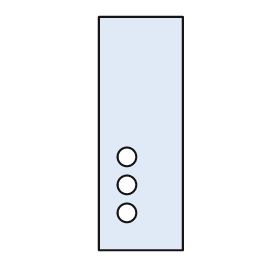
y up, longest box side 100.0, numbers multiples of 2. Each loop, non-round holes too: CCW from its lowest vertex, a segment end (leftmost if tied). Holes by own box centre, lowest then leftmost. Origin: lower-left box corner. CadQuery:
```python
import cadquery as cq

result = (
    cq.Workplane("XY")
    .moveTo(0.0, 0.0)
    .lineTo(36.0, 0.0)
    .lineTo(36.0, 100.0)
    .lineTo(0.0, 100.0)
    .close()
    .moveTo(12.0, 16.0)
    .circle(4.0)
    .moveTo(12.0, 28.0)
    .circle(4.0)
    .moveTo(12.0, 40.0)
    .circle(4.0)
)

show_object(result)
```